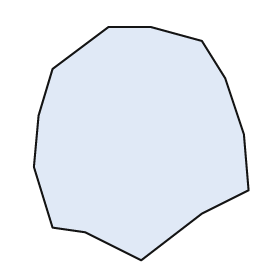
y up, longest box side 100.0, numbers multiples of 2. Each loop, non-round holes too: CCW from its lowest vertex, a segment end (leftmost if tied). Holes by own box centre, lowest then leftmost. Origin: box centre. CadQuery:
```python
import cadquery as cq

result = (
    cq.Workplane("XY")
    .moveTo(0.0, -50.0)
    .lineTo(26.0, -30.0)
    .lineTo(46.0, -20.0)
    .lineTo(44.0, 4.0)
    .lineTo(36.0, 28.0)
    .lineTo(26.0, 44.0)
    .lineTo(4.0, 50.0)
    .lineTo(-14.0, 50.0)
    .lineTo(-38.0, 32.0)
    .lineTo(-44.0, 12.0)
    .lineTo(-46.0, -10.0)
    .lineTo(-38.0, -36.0)
    .lineTo(-24.0, -38.0)
    .close()
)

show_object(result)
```